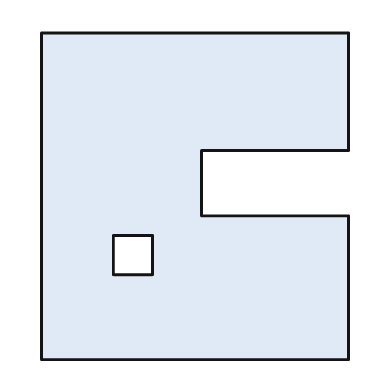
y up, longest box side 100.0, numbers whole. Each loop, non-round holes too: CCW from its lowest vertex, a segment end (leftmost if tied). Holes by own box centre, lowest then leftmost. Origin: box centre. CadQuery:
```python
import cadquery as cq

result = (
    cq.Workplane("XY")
    .moveTo(-47.0, -50.0)
    .lineTo(47.0, -50.0)
    .lineTo(47.0, -6.0)
    .lineTo(2.0, -6.0)
    .lineTo(2.0, 14.0)
    .lineTo(47.0, 14.0)
    .lineTo(47.0, 50.0)
    .lineTo(-47.0, 50.0)
    .close()
    .moveTo(-25.0, -24.0)
    .lineTo(-13.0, -24.0)
    .lineTo(-13.0, -12.0)
    .lineTo(-25.0, -12.0)
    .close()
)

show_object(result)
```